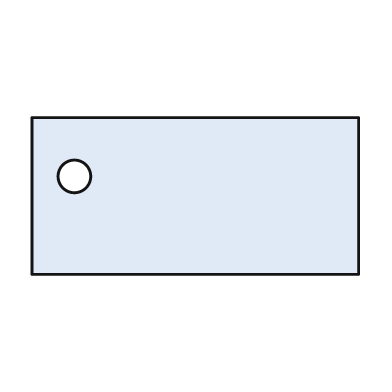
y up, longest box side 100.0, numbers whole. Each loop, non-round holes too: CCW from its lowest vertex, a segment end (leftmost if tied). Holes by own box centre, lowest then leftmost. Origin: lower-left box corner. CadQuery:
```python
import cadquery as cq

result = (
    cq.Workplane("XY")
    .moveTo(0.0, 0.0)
    .lineTo(100.0, 0.0)
    .lineTo(100.0, 48.0)
    .lineTo(0.0, 48.0)
    .close()
    .moveTo(13.0, 30.0)
    .circle(5.0)
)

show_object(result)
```